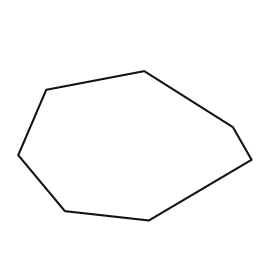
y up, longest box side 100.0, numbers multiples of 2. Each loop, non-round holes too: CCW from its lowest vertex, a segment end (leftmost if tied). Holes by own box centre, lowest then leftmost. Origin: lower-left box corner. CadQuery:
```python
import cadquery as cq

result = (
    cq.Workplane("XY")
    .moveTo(56.0, 0.0)
    .lineTo(100.0, 26.0)
    .lineTo(92.0, 40.0)
    .lineTo(54.0, 64.0)
    .lineTo(12.0, 56.0)
    .lineTo(0.0, 28.0)
    .lineTo(20.0, 4.0)
    .close()
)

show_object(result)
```